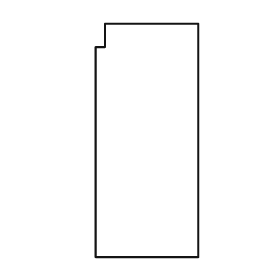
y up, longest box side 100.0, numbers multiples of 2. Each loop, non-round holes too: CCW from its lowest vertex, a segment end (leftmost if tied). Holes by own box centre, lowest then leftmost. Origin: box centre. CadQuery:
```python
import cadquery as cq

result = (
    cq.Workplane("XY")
    .moveTo(-22.0, -50.0)
    .lineTo(22.0, -50.0)
    .lineTo(22.0, 50.0)
    .lineTo(-18.0, 50.0)
    .lineTo(-18.0, 40.0)
    .lineTo(-22.0, 40.0)
    .close()
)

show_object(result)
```